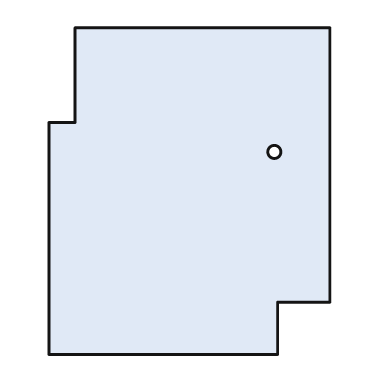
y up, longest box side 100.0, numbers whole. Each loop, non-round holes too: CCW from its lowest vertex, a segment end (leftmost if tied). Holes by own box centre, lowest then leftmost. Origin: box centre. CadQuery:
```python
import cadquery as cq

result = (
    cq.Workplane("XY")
    .moveTo(-43.0, -50.0)
    .lineTo(27.0, -50.0)
    .lineTo(27.0, -34.0)
    .lineTo(43.0, -34.0)
    .lineTo(43.0, 50.0)
    .lineTo(-35.0, 50.0)
    .lineTo(-35.0, 21.0)
    .lineTo(-43.0, 21.0)
    .close()
    .moveTo(26.0, 12.0)
    .circle(2.0)
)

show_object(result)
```